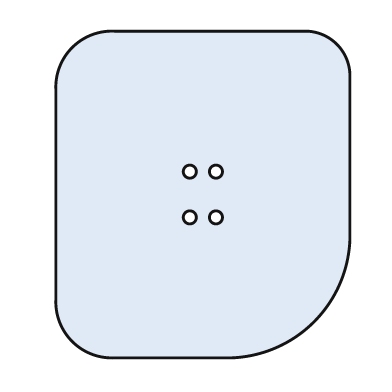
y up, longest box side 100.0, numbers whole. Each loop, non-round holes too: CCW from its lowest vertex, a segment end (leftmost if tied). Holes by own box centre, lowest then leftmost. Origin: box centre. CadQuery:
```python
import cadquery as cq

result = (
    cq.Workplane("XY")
    .moveTo(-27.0, -50.0)
    .lineTo(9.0, -50.0)
    .threePointArc((34.0, -39.0), (45.0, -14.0))
    .lineTo(45.0, 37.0)
    .threePointArc((41.0, 46.0), (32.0, 50.0))
    .lineTo(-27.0, 50.0)
    .threePointArc((-40.0, 45.0), (-45.0, 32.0))
    .lineTo(-45.0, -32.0)
    .threePointArc((-40.0, -45.0), (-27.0, -50.0))
    .close()
    .moveTo(-4.0, -7.0)
    .circle(2.0)
    .moveTo(4.0, -7.0)
    .circle(2.0)
    .moveTo(-4.0, 7.0)
    .circle(2.0)
    .moveTo(4.0, 7.0)
    .circle(2.0)
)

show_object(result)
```